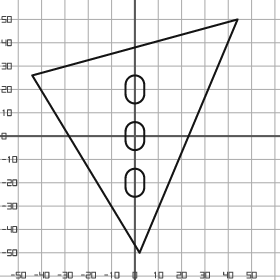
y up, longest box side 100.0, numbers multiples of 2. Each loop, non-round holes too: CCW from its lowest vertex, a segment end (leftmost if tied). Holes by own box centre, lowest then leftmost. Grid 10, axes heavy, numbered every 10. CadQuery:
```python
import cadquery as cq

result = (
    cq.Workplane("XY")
    .moveTo(2.0, -50.0)
    .lineTo(44.0, 50.0)
    .lineTo(-44.0, 26.0)
    .close()
    .moveTo(-4.0, -22.0)
    .threePointArc((0.0, -26.0), (4.0, -22.0))
    .lineTo(4.0, -18.0)
    .threePointArc((0.0, -14.0), (-4.0, -18.0))
    .close()
    .moveTo(-4.0, -2.0)
    .threePointArc((0.0, -6.0), (4.0, -2.0))
    .lineTo(4.0, 2.0)
    .threePointArc((0.0, 6.0), (-4.0, 2.0))
    .close()
    .moveTo(-4.0, 18.0)
    .threePointArc((0.0, 14.0), (4.0, 18.0))
    .lineTo(4.0, 22.0)
    .threePointArc((0.0, 26.0), (-4.0, 22.0))
    .close()
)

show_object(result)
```